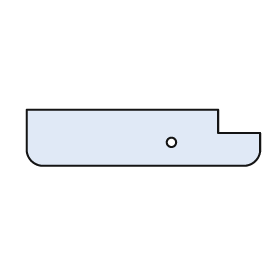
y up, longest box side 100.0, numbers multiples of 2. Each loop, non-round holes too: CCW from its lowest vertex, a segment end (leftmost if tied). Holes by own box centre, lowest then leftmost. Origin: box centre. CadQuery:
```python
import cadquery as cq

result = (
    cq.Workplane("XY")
    .moveTo(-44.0, -12.0)
    .lineTo(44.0, -12.0)
    .threePointArc((48.0, -10.0), (50.0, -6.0))
    .lineTo(50.0, 2.0)
    .lineTo(32.0, 2.0)
    .lineTo(32.0, 12.0)
    .lineTo(-50.0, 12.0)
    .lineTo(-50.0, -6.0)
    .threePointArc((-48.0, -10.0), (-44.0, -12.0))
    .close()
    .moveTo(12.0, -2.0)
    .circle(2.0)
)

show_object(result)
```